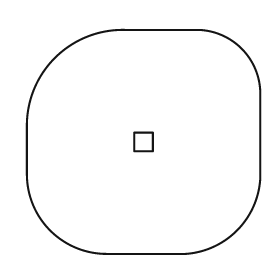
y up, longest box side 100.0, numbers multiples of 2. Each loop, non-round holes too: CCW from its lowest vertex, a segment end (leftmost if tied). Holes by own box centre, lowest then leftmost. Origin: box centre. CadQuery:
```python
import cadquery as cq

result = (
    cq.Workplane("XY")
    .moveTo(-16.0, -48.0)
    .lineTo(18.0, -48.0)
    .threePointArc((40.0, -38.0), (50.0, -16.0))
    .lineTo(50.0, 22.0)
    .threePointArc((42.0, 40.0), (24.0, 48.0))
    .lineTo(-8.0, 48.0)
    .threePointArc((-38.0, 36.0), (-50.0, 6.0))
    .lineTo(-50.0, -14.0)
    .threePointArc((-40.0, -38.0), (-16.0, -48.0))
    .close()
    .moveTo(-4.0, -4.0)
    .lineTo(4.0, -4.0)
    .lineTo(4.0, 4.0)
    .lineTo(-4.0, 4.0)
    .close()
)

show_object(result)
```